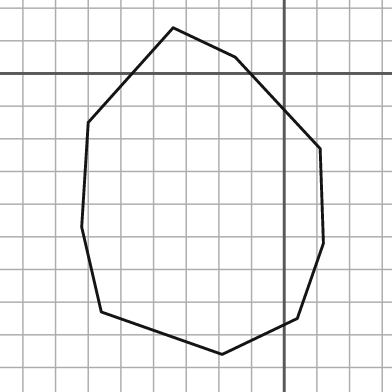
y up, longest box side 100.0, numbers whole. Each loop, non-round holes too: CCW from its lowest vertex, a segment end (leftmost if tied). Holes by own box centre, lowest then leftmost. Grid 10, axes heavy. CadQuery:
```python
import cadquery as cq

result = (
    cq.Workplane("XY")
    .moveTo(-19.0, -86.0)
    .lineTo(4.0, -75.0)
    .lineTo(12.0, -52.0)
    .lineTo(11.0, -23.0)
    .lineTo(-15.0, 5.0)
    .lineTo(-34.0, 14.0)
    .lineTo(-60.0, -15.0)
    .lineTo(-62.0, -47.0)
    .lineTo(-56.0, -73.0)
    .close()
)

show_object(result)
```